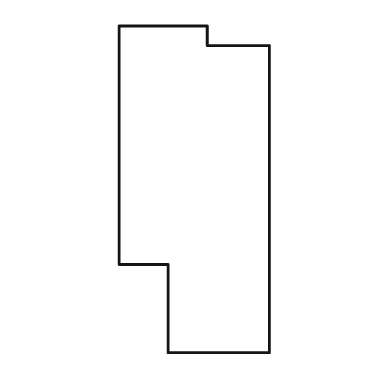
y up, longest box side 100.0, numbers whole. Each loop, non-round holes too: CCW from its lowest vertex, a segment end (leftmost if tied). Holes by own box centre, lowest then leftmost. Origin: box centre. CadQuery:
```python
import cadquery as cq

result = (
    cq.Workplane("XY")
    .moveTo(-8.0, -50.0)
    .lineTo(23.0, -50.0)
    .lineTo(23.0, 44.0)
    .lineTo(4.0, 44.0)
    .lineTo(4.0, 50.0)
    .lineTo(-23.0, 50.0)
    .lineTo(-23.0, -23.0)
    .lineTo(-8.0, -23.0)
    .close()
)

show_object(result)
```